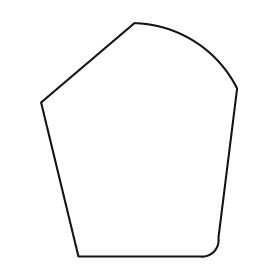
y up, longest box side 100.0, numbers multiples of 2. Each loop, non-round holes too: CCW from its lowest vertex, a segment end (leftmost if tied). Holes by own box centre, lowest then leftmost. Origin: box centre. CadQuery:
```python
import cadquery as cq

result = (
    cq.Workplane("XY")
    .moveTo(-26.0, -50.0)
    .lineTo(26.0, -50.0)
    .threePointArc((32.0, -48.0), (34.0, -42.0))
    .lineTo(42.0, 22.0)
    .threePointArc((24.0, 42.0), (-2.0, 50.0))
    .lineTo(-42.0, 16.0)
    .close()
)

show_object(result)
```